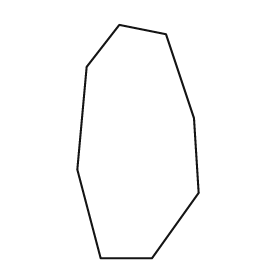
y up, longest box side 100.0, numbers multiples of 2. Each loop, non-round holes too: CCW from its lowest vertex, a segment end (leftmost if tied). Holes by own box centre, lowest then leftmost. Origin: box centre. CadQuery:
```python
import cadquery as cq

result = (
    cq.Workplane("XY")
    .moveTo(-16.0, -50.0)
    .lineTo(6.0, -50.0)
    .lineTo(26.0, -22.0)
    .lineTo(24.0, 10.0)
    .lineTo(12.0, 46.0)
    .lineTo(-8.0, 50.0)
    .lineTo(-22.0, 32.0)
    .lineTo(-26.0, -12.0)
    .close()
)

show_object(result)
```